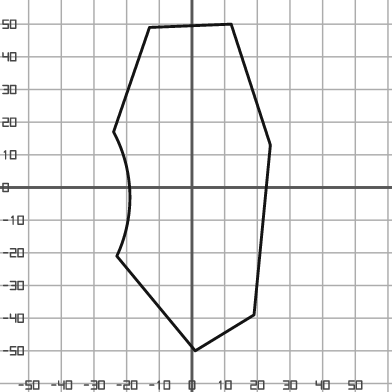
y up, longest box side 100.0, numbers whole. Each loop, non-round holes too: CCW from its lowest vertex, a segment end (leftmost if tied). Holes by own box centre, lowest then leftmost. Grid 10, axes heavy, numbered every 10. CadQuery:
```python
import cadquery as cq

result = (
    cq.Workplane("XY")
    .moveTo(1.0, -50.0)
    .lineTo(19.0, -39.0)
    .lineTo(24.0, 13.0)
    .lineTo(12.0, 50.0)
    .lineTo(-13.0, 49.0)
    .lineTo(-24.0, 17.0)
    .threePointArc((-19.0, -2.0), (-23.0, -21.0))
    .close()
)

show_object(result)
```